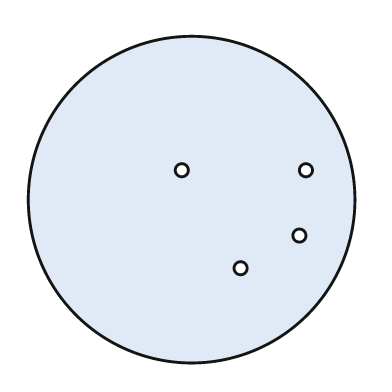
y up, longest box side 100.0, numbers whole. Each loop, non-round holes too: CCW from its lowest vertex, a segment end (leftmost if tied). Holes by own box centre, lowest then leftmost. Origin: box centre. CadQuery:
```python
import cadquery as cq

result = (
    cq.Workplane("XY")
    .moveTo(0.0, 0.0)
    .circle(50.0)
    .moveTo(15.0, -21.0)
    .circle(2.0)
    .moveTo(33.0, -11.0)
    .circle(2.0)
    .moveTo(-3.0, 9.0)
    .circle(2.0)
    .moveTo(35.0, 9.0)
    .circle(2.0)
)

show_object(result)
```